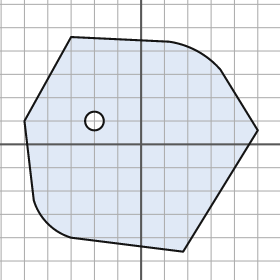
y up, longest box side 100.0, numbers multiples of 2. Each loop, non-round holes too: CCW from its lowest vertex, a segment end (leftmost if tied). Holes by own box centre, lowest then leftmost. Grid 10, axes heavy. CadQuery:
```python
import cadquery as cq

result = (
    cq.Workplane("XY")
    .moveTo(18.0, -46.0)
    .lineTo(50.0, 6.0)
    .lineTo(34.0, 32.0)
    .threePointArc((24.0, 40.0), (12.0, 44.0))
    .lineTo(-30.0, 46.0)
    .lineTo(-50.0, 10.0)
    .lineTo(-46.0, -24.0)
    .threePointArc((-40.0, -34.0), (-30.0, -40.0))
    .close()
    .moveTo(-20.0, 10.0)
    .circle(4.0)
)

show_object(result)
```